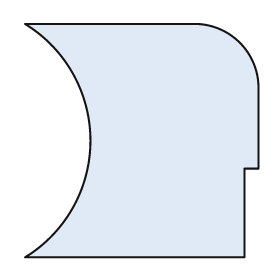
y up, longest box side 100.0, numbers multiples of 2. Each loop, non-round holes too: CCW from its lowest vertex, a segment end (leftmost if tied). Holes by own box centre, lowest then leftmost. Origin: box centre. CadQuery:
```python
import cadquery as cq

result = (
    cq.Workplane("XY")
    .moveTo(-50.0, -50.0)
    .lineTo(44.0, -50.0)
    .lineTo(44.0, -12.0)
    .lineTo(50.0, -12.0)
    .lineTo(50.0, 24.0)
    .threePointArc((42.0, 42.0), (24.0, 50.0))
    .lineTo(-50.0, 50.0)
    .threePointArc((-22.0, 0.0), (-50.0, -50.0))
    .close()
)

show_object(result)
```